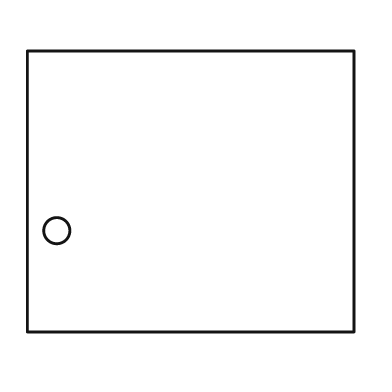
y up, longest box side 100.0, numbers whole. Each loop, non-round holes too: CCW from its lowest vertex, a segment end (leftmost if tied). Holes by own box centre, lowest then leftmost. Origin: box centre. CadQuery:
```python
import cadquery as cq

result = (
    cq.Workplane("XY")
    .moveTo(-50.0, -43.0)
    .lineTo(50.0, -43.0)
    .lineTo(50.0, 43.0)
    .lineTo(-50.0, 43.0)
    .close()
    .moveTo(-41.0, -12.0)
    .circle(4.0)
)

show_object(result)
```